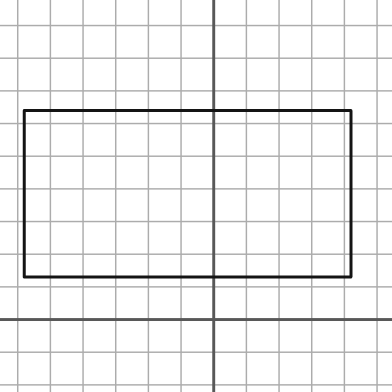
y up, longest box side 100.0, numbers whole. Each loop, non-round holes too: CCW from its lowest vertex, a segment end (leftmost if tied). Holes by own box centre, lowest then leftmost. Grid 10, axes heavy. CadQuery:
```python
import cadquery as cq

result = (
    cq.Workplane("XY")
    .moveTo(-58.0, 13.0)
    .lineTo(42.0, 13.0)
    .lineTo(42.0, 64.0)
    .lineTo(-58.0, 64.0)
    .close()
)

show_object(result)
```